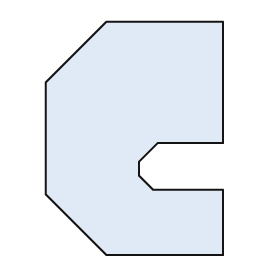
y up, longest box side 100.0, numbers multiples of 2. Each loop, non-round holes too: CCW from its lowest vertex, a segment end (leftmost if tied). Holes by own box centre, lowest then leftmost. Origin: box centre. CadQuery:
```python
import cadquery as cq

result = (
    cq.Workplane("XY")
    .moveTo(-12.0, -50.0)
    .lineTo(38.0, -50.0)
    .lineTo(38.0, -22.0)
    .lineTo(8.0, -22.0)
    .lineTo(2.0, -16.0)
    .lineTo(2.0, -10.0)
    .lineTo(10.0, -2.0)
    .lineTo(38.0, -2.0)
    .lineTo(38.0, 50.0)
    .lineTo(-12.0, 50.0)
    .lineTo(-38.0, 24.0)
    .lineTo(-38.0, -24.0)
    .close()
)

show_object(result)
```